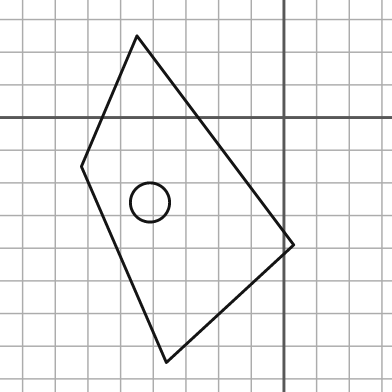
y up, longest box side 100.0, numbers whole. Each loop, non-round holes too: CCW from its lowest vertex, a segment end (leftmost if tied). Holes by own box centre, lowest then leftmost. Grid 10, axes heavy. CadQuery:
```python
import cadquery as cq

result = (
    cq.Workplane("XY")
    .moveTo(-36.0, -75.0)
    .lineTo(3.0, -39.0)
    .lineTo(-45.0, 25.0)
    .lineTo(-62.0, -15.0)
    .close()
    .moveTo(-41.0, -26.0)
    .circle(6.0)
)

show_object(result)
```